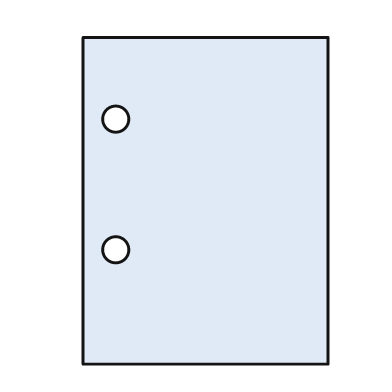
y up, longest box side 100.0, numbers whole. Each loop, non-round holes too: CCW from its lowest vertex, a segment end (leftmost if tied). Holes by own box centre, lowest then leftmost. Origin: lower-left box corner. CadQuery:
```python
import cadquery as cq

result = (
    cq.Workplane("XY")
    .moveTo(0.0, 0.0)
    .lineTo(75.0, 0.0)
    .lineTo(75.0, 100.0)
    .lineTo(0.0, 100.0)
    .close()
    .moveTo(10.0, 35.0)
    .circle(4.0)
    .moveTo(10.0, 75.0)
    .circle(4.0)
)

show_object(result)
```